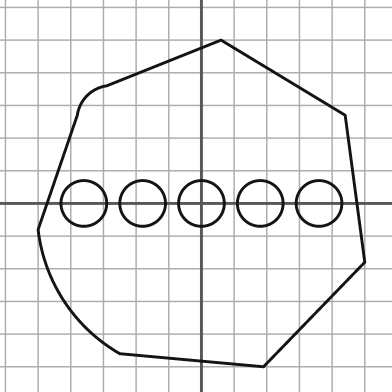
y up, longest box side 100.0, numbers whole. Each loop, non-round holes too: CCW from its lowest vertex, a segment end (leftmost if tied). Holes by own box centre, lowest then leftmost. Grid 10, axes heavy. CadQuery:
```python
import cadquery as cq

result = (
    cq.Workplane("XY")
    .moveTo(19.0, -50.0)
    .lineTo(50.0, -18.0)
    .lineTo(44.0, 27.0)
    .lineTo(6.0, 50.0)
    .lineTo(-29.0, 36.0)
    .threePointArc((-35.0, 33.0), (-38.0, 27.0))
    .lineTo(-50.0, -8.0)
    .threePointArc((-42.0, -30.0), (-25.0, -46.0))
    .close()
    .moveTo(-36.0, 0.0)
    .circle(7.0)
    .moveTo(-18.0, 0.0)
    .circle(7.0)
    .moveTo(0.0, 0.0)
    .circle(7.0)
    .moveTo(18.0, 0.0)
    .circle(7.0)
    .moveTo(36.0, 0.0)
    .circle(7.0)
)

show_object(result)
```